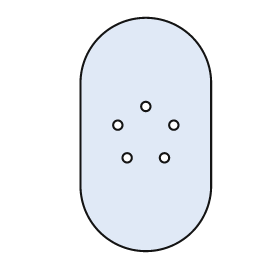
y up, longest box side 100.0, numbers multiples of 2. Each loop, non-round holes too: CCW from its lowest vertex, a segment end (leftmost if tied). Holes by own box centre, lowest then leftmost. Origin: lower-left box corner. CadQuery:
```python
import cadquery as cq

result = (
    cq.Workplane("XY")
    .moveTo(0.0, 28.0)
    .threePointArc((28.0, 0.0), (56.0, 28.0))
    .lineTo(56.0, 72.0)
    .threePointArc((28.0, 100.0), (0.0, 72.0))
    .close()
    .moveTo(20.0, 40.0)
    .circle(2.0)
    .moveTo(36.0, 40.0)
    .circle(2.0)
    .moveTo(16.0, 54.0)
    .circle(2.0)
    .moveTo(40.0, 54.0)
    .circle(2.0)
    .moveTo(28.0, 62.0)
    .circle(2.0)
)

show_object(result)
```